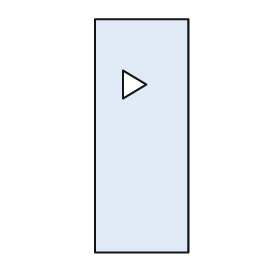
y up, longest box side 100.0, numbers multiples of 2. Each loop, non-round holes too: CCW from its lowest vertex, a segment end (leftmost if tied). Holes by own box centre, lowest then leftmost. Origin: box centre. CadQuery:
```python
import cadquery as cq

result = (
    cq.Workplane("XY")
    .moveTo(-20.0, -50.0)
    .lineTo(20.0, -50.0)
    .lineTo(20.0, 50.0)
    .lineTo(-20.0, 50.0)
    .close()
    .moveTo(-8.0, 16.0)
    .lineTo(2.0, 22.0)
    .lineTo(-8.0, 28.0)
    .close()
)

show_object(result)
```